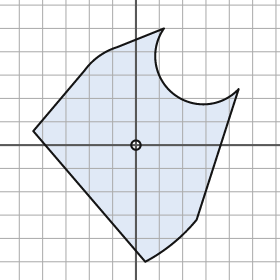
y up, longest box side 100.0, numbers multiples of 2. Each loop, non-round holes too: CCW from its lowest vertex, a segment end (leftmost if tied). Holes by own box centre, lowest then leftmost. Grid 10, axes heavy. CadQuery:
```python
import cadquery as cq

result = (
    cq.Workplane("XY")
    .moveTo(4.0, -50.0)
    .threePointArc((16.0, -42.0), (26.0, -32.0))
    .lineTo(44.0, 24.0)
    .threePointArc((16.0, 22.0), (12.0, 50.0))
    .lineTo(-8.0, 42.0)
    .threePointArc((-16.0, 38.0), (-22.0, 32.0))
    .lineTo(-44.0, 6.0)
    .close()
    .moveTo(0.0, 0.0)
    .circle(2.0)
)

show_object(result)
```